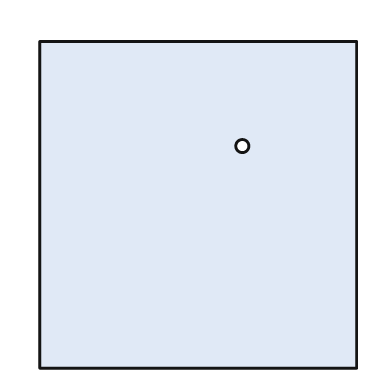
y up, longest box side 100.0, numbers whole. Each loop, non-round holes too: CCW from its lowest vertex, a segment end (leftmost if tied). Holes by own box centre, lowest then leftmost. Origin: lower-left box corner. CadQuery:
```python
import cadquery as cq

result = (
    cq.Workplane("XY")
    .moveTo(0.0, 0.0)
    .lineTo(97.0, 0.0)
    .lineTo(97.0, 100.0)
    .lineTo(0.0, 100.0)
    .close()
    .moveTo(62.0, 68.0)
    .circle(2.0)
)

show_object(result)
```